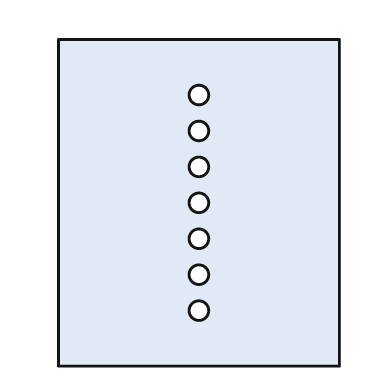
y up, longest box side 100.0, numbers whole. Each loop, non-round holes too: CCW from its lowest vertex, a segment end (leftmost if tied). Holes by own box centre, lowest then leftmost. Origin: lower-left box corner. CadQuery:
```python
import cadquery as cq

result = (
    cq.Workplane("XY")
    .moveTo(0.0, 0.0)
    .lineTo(86.0, 0.0)
    .lineTo(86.0, 100.0)
    .lineTo(0.0, 100.0)
    .close()
    .moveTo(43.0, 17.0)
    .circle(3.0)
    .moveTo(43.0, 28.0)
    .circle(3.0)
    .moveTo(43.0, 39.0)
    .circle(3.0)
    .moveTo(43.0, 50.0)
    .circle(3.0)
    .moveTo(43.0, 61.0)
    .circle(3.0)
    .moveTo(43.0, 72.0)
    .circle(3.0)
    .moveTo(43.0, 83.0)
    .circle(3.0)
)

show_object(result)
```